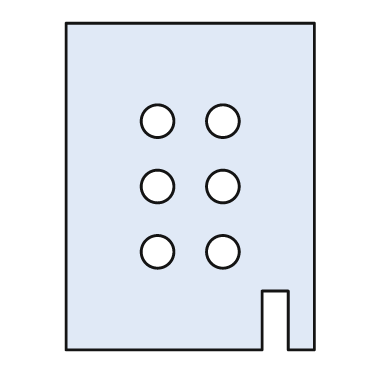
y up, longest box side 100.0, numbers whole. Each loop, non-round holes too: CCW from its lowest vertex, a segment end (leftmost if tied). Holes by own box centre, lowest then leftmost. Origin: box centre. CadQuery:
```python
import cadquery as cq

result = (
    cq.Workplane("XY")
    .moveTo(-38.0, -50.0)
    .lineTo(22.0, -50.0)
    .lineTo(22.0, -32.0)
    .lineTo(30.0, -32.0)
    .lineTo(30.0, -50.0)
    .lineTo(38.0, -50.0)
    .lineTo(38.0, 50.0)
    .lineTo(-38.0, 50.0)
    .close()
    .moveTo(-10.0, -20.0)
    .circle(5.0)
    .moveTo(10.0, -20.0)
    .circle(5.0)
    .moveTo(-10.0, 0.0)
    .circle(5.0)
    .moveTo(10.0, 0.0)
    .circle(5.0)
    .moveTo(-10.0, 20.0)
    .circle(5.0)
    .moveTo(10.0, 20.0)
    .circle(5.0)
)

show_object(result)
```